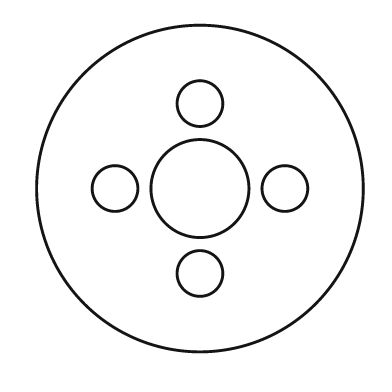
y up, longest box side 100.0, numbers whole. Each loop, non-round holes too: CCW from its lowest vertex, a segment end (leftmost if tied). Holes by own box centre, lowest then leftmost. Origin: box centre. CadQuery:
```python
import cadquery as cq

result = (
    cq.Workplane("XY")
    .moveTo(0.0, 0.0)
    .circle(50.0)
    .moveTo(0.0, -26.0)
    .circle(7.0)
    .moveTo(-26.0, 0.0)
    .circle(7.0)
    .moveTo(0.0, 0.0)
    .circle(15.0)
    .moveTo(26.0, 0.0)
    .circle(7.0)
    .moveTo(0.0, 26.0)
    .circle(7.0)
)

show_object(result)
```